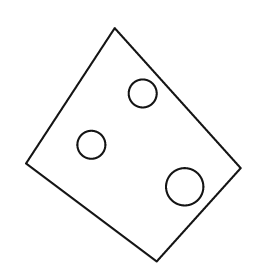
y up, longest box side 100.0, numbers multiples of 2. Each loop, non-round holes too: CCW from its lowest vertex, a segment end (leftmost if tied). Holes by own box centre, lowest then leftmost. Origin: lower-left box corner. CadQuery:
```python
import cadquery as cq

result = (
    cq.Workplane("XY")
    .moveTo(56.0, 0.0)
    .lineTo(92.0, 40.0)
    .lineTo(38.0, 100.0)
    .lineTo(0.0, 42.0)
    .close()
    .moveTo(68.0, 32.0)
    .circle(8.0)
    .moveTo(28.0, 50.0)
    .circle(6.0)
    .moveTo(50.0, 72.0)
    .circle(6.0)
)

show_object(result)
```